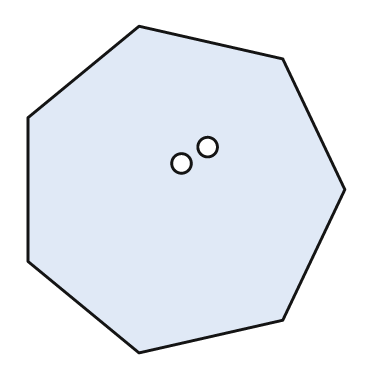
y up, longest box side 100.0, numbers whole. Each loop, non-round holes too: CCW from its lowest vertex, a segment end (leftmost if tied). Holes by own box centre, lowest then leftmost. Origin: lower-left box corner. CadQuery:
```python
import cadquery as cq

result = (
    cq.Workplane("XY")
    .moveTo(34.0, 0.0)
    .lineTo(78.0, 10.0)
    .lineTo(97.0, 50.0)
    .lineTo(78.0, 90.0)
    .lineTo(34.0, 100.0)
    .lineTo(0.0, 72.0)
    .lineTo(0.0, 28.0)
    .close()
    .moveTo(47.0, 58.0)
    .circle(3.0)
    .moveTo(55.0, 63.0)
    .circle(3.0)
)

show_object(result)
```